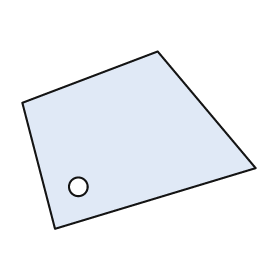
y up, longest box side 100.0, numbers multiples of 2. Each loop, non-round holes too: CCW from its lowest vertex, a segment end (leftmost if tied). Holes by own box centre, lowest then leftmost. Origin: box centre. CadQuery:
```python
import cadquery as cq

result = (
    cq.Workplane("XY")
    .moveTo(-36.0, -38.0)
    .lineTo(50.0, -12.0)
    .lineTo(8.0, 38.0)
    .lineTo(-50.0, 16.0)
    .close()
    .moveTo(-26.0, -20.0)
    .circle(4.0)
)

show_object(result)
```